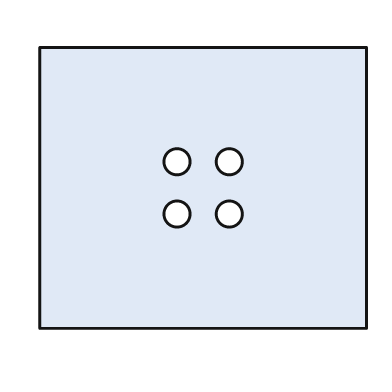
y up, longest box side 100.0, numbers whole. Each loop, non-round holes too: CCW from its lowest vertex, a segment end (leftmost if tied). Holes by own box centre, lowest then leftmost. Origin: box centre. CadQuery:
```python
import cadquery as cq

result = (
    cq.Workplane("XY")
    .moveTo(-50.0, -43.0)
    .lineTo(50.0, -43.0)
    .lineTo(50.0, 43.0)
    .lineTo(-50.0, 43.0)
    .close()
    .moveTo(-8.0, -8.0)
    .circle(4.0)
    .moveTo(8.0, -8.0)
    .circle(4.0)
    .moveTo(-8.0, 8.0)
    .circle(4.0)
    .moveTo(8.0, 8.0)
    .circle(4.0)
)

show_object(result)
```